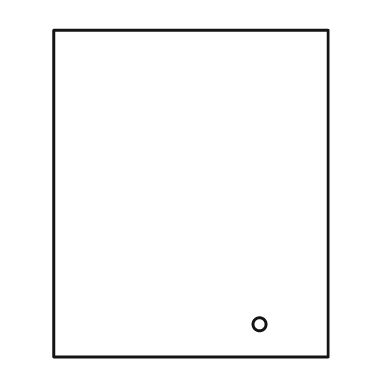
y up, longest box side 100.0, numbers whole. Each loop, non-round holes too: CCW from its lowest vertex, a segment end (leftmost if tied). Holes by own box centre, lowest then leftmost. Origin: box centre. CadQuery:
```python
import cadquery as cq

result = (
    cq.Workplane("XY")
    .moveTo(-42.0, -50.0)
    .lineTo(42.0, -50.0)
    .lineTo(42.0, 50.0)
    .lineTo(-42.0, 50.0)
    .close()
    .moveTo(21.0, -40.0)
    .circle(2.0)
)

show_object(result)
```